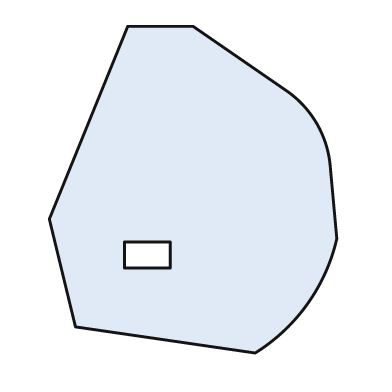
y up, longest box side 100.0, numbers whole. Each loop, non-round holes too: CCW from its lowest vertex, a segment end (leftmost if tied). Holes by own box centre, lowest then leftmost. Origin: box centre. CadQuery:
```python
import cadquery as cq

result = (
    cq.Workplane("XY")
    .moveTo(19.0, -50.0)
    .threePointArc((35.0, -35.0), (44.0, -15.0))
    .lineTo(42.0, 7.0)
    .threePointArc((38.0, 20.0), (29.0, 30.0))
    .lineTo(0.0, 50.0)
    .lineTo(-20.0, 50.0)
    .lineTo(-44.0, -9.0)
    .lineTo(-36.0, -42.0)
    .close()
    .moveTo(-21.0, -24.0)
    .lineTo(-7.0, -24.0)
    .lineTo(-7.0, -16.0)
    .lineTo(-21.0, -16.0)
    .close()
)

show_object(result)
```